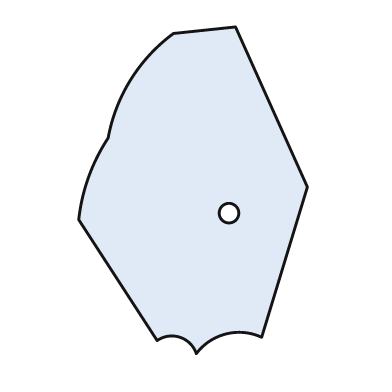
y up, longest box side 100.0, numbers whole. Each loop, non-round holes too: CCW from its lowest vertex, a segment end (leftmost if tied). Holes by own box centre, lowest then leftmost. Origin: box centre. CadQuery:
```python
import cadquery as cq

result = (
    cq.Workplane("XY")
    .moveTo(1.0, -50.0)
    .threePointArc((10.0, -44.0), (21.0, -45.0))
    .lineTo(35.0, 1.0)
    .lineTo(13.0, 50.0)
    .lineTo(-6.0, 48.0)
    .threePointArc((-19.0, 34.0), (-26.0, 16.0))
    .threePointArc((-32.0, 4.0), (-35.0, -9.0))
    .lineTo(-11.0, -46.0)
    .threePointArc((-4.0, -45.0), (1.0, -50.0))
    .close()
    .moveTo(11.0, -7.0)
    .circle(3.0)
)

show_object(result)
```